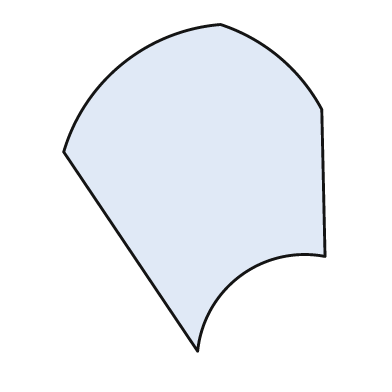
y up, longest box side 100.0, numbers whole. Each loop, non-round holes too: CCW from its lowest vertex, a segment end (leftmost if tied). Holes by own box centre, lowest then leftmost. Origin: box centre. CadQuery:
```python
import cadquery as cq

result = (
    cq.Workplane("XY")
    .moveTo(1.0, -50.0)
    .threePointArc((14.0, -27.0), (40.0, -21.0))
    .lineTo(39.0, 24.0)
    .threePointArc((26.0, 40.0), (8.0, 50.0))
    .threePointArc((-22.0, 38.0), (-40.0, 11.0))
    .close()
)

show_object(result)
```